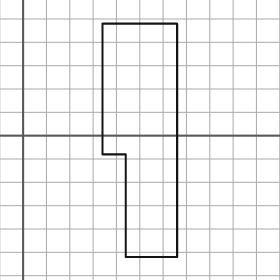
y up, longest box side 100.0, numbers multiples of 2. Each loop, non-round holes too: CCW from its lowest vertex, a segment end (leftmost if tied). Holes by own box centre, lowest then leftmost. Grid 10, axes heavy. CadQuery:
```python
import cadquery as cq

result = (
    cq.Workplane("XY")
    .moveTo(44.0, -52.0)
    .lineTo(66.0, -52.0)
    .lineTo(66.0, 48.0)
    .lineTo(34.0, 48.0)
    .lineTo(34.0, -8.0)
    .lineTo(44.0, -8.0)
    .close()
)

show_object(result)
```